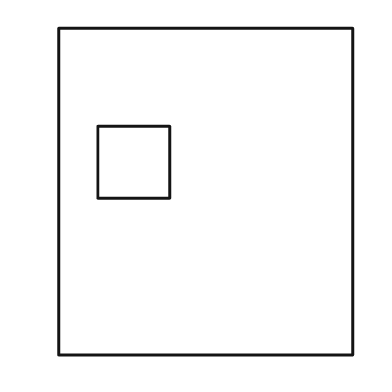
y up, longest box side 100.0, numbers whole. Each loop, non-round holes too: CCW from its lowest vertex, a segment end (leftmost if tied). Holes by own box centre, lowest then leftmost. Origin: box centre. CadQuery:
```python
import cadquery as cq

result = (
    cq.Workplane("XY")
    .moveTo(-45.0, -50.0)
    .lineTo(45.0, -50.0)
    .lineTo(45.0, 50.0)
    .lineTo(-45.0, 50.0)
    .close()
    .moveTo(-33.0, -2.0)
    .lineTo(-11.0, -2.0)
    .lineTo(-11.0, 20.0)
    .lineTo(-33.0, 20.0)
    .close()
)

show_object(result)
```